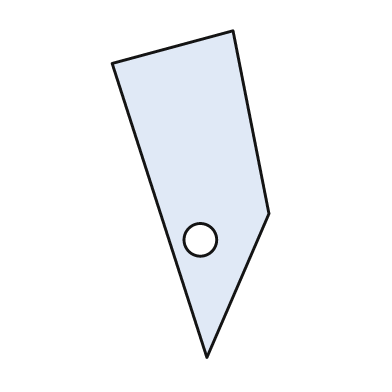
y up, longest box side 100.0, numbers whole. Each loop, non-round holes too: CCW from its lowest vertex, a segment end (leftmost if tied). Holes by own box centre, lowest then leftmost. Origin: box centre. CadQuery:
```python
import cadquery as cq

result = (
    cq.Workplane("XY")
    .moveTo(5.0, -50.0)
    .lineTo(24.0, -6.0)
    .lineTo(13.0, 50.0)
    .lineTo(-24.0, 40.0)
    .close()
    .moveTo(3.0, -14.0)
    .circle(5.0)
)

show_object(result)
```